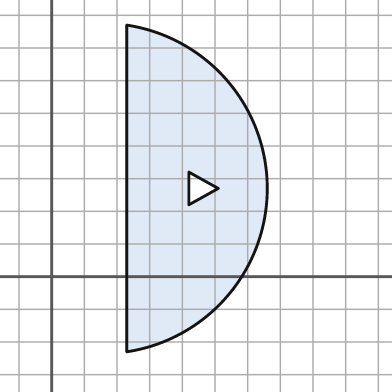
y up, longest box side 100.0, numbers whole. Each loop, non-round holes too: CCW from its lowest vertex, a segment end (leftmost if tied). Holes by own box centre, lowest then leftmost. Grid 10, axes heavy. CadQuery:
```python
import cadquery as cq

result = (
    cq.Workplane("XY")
    .moveTo(23.0, -23.0)
    .threePointArc((66.0, 27.0), (23.0, 77.0))
    .close()
    .moveTo(42.0, 22.0)
    .lineTo(51.0, 27.0)
    .lineTo(42.0, 32.0)
    .close()
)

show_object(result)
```